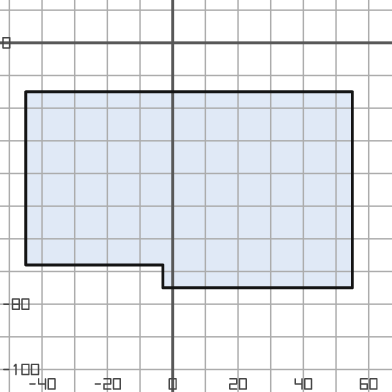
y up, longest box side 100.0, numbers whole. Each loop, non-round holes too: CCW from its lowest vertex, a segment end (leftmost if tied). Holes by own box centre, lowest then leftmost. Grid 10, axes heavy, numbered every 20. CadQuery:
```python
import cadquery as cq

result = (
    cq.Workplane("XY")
    .moveTo(-3.0, -75.0)
    .lineTo(55.0, -75.0)
    .lineTo(55.0, -15.0)
    .lineTo(-45.0, -15.0)
    .lineTo(-45.0, -68.0)
    .lineTo(-3.0, -68.0)
    .close()
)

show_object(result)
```